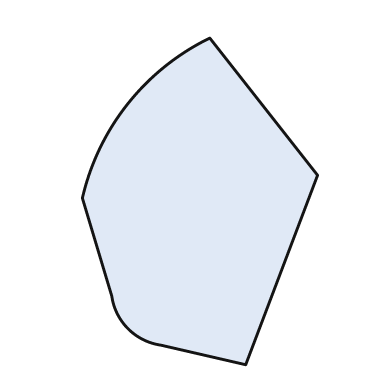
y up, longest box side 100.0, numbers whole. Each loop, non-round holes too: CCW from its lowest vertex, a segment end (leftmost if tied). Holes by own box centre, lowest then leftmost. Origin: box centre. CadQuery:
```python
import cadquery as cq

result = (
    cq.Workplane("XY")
    .moveTo(14.0, -50.0)
    .lineTo(36.0, 8.0)
    .lineTo(3.0, 50.0)
    .threePointArc((-22.0, 30.0), (-36.0, 1.0))
    .lineTo(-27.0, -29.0)
    .threePointArc((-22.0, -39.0), (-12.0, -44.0))
    .close()
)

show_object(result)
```